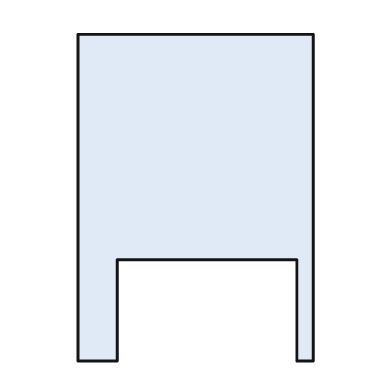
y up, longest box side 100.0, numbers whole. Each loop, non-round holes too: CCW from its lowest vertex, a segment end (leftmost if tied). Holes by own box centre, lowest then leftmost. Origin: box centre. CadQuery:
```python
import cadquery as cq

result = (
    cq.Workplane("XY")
    .moveTo(-36.0, -50.0)
    .lineTo(-24.0, -50.0)
    .lineTo(-24.0, -19.0)
    .lineTo(31.0, -19.0)
    .lineTo(31.0, -50.0)
    .lineTo(36.0, -50.0)
    .lineTo(36.0, 50.0)
    .lineTo(-36.0, 50.0)
    .close()
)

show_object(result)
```